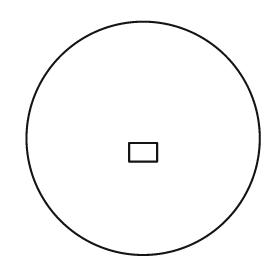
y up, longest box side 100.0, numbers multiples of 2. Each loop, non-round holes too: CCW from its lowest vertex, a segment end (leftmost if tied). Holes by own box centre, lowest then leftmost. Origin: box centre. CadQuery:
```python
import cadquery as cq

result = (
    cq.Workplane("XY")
    .moveTo(0.0, 0.0)
    .circle(50.0)
    .moveTo(-6.0, -10.0)
    .lineTo(6.0, -10.0)
    .lineTo(6.0, -2.0)
    .lineTo(-6.0, -2.0)
    .close()
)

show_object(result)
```